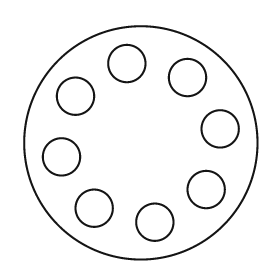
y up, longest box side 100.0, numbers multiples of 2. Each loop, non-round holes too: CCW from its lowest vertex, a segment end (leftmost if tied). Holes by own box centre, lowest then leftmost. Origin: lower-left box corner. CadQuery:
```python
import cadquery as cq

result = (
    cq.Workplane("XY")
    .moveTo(50.0, 50.0)
    .circle(50.0)
    .moveTo(56.0, 16.0)
    .circle(8.0)
    .moveTo(30.0, 22.0)
    .circle(8.0)
    .moveTo(78.0, 30.0)
    .circle(8.0)
    .moveTo(16.0, 44.0)
    .circle(8.0)
    .moveTo(84.0, 56.0)
    .circle(8.0)
    .moveTo(22.0, 70.0)
    .circle(8.0)
    .moveTo(70.0, 78.0)
    .circle(8.0)
    .moveTo(44.0, 84.0)
    .circle(8.0)
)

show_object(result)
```